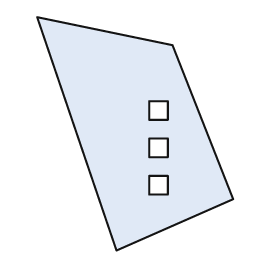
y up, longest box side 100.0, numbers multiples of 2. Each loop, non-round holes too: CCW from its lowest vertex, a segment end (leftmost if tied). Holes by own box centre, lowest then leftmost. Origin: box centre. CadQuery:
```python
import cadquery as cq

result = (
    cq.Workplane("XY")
    .moveTo(-8.0, -50.0)
    .lineTo(42.0, -28.0)
    .lineTo(16.0, 38.0)
    .lineTo(-42.0, 50.0)
    .close()
    .moveTo(6.0, -26.0)
    .lineTo(14.0, -26.0)
    .lineTo(14.0, -18.0)
    .lineTo(6.0, -18.0)
    .close()
    .moveTo(6.0, -10.0)
    .lineTo(14.0, -10.0)
    .lineTo(14.0, -2.0)
    .lineTo(6.0, -2.0)
    .close()
    .moveTo(6.0, 6.0)
    .lineTo(14.0, 6.0)
    .lineTo(14.0, 14.0)
    .lineTo(6.0, 14.0)
    .close()
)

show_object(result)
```